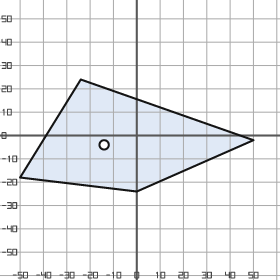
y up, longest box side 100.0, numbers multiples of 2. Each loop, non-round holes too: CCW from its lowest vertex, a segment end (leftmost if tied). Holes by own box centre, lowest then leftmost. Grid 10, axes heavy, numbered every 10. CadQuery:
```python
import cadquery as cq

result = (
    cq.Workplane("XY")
    .moveTo(0.0, -24.0)
    .lineTo(50.0, -2.0)
    .lineTo(-24.0, 24.0)
    .lineTo(-50.0, -18.0)
    .close()
    .moveTo(-14.0, -4.0)
    .circle(2.0)
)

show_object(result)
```